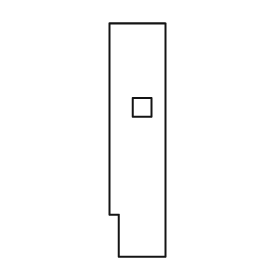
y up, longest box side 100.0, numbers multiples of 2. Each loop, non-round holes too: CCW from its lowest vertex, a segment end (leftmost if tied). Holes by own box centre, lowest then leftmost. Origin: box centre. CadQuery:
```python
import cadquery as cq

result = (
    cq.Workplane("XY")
    .moveTo(-8.0, -50.0)
    .lineTo(12.0, -50.0)
    .lineTo(12.0, 50.0)
    .lineTo(-12.0, 50.0)
    .lineTo(-12.0, -32.0)
    .lineTo(-8.0, -32.0)
    .close()
    .moveTo(-2.0, 10.0)
    .lineTo(6.0, 10.0)
    .lineTo(6.0, 18.0)
    .lineTo(-2.0, 18.0)
    .close()
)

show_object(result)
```